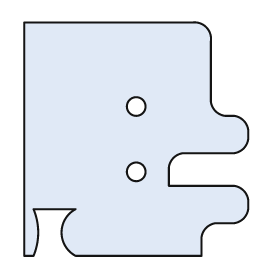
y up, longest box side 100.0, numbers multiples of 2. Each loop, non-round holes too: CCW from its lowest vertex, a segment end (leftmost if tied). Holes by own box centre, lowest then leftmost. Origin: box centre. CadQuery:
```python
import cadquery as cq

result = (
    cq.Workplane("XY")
    .moveTo(-48.0, -50.0)
    .lineTo(-44.0, -50.0)
    .threePointArc((-42.0, -40.0), (-44.0, -30.0))
    .lineTo(-26.0, -30.0)
    .threePointArc((-32.0, -40.0), (-26.0, -50.0))
    .lineTo(28.0, -50.0)
    .lineTo(28.0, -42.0)
    .threePointArc((30.0, -38.0), (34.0, -36.0))
    .lineTo(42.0, -36.0)
    .threePointArc((46.0, -34.0), (48.0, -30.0))
    .lineTo(48.0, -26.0)
    .threePointArc((46.0, -22.0), (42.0, -20.0))
    .lineTo(14.0, -20.0)
    .lineTo(14.0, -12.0)
    .threePointArc((16.0, -8.0), (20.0, -6.0))
    .lineTo(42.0, -6.0)
    .threePointArc((46.0, -4.0), (48.0, 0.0))
    .lineTo(48.0, 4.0)
    .threePointArc((46.0, 8.0), (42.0, 10.0))
    .lineTo(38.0, 10.0)
    .threePointArc((34.0, 12.0), (32.0, 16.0))
    .lineTo(32.0, 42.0)
    .threePointArc((30.0, 48.0), (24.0, 50.0))
    .lineTo(-48.0, 50.0)
    .close()
    .moveTo(0.0, -14.0)
    .circle(4.0)
    .moveTo(0.0, 14.0)
    .circle(4.0)
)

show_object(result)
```